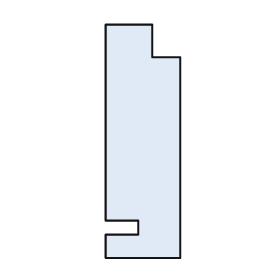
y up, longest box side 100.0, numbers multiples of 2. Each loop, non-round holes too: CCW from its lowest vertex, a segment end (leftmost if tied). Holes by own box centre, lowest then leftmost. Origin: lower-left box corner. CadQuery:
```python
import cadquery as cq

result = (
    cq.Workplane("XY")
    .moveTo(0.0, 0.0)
    .lineTo(32.0, 0.0)
    .lineTo(32.0, 86.0)
    .lineTo(20.0, 86.0)
    .lineTo(20.0, 100.0)
    .lineTo(0.0, 100.0)
    .lineTo(0.0, 16.0)
    .lineTo(14.0, 16.0)
    .lineTo(14.0, 10.0)
    .lineTo(0.0, 10.0)
    .close()
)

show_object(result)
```